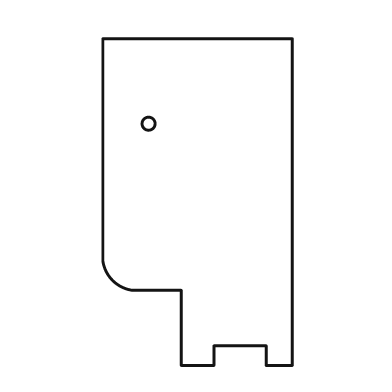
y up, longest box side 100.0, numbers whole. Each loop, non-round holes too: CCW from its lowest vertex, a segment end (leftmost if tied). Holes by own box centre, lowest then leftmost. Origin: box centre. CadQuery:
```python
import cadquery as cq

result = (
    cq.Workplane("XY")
    .moveTo(-5.0, -50.0)
    .lineTo(5.0, -50.0)
    .lineTo(5.0, -44.0)
    .lineTo(21.0, -44.0)
    .lineTo(21.0, -50.0)
    .lineTo(29.0, -50.0)
    .lineTo(29.0, 50.0)
    .lineTo(-29.0, 50.0)
    .lineTo(-29.0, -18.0)
    .threePointArc((-26.0, -24.0), (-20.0, -27.0))
    .lineTo(-5.0, -27.0)
    .close()
    .moveTo(-15.0, 24.0)
    .circle(2.0)
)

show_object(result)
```